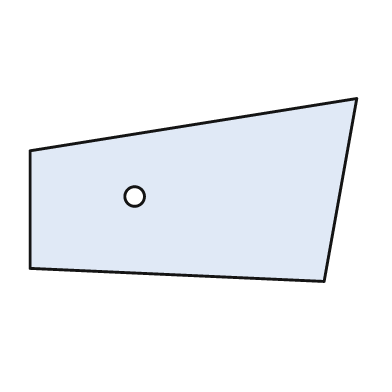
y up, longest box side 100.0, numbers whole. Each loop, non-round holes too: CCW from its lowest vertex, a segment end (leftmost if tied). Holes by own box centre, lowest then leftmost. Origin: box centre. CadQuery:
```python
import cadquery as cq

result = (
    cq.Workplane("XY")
    .moveTo(40.0, -28.0)
    .lineTo(50.0, 28.0)
    .lineTo(-50.0, 12.0)
    .lineTo(-50.0, -24.0)
    .close()
    .moveTo(-18.0, -2.0)
    .circle(3.0)
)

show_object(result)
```